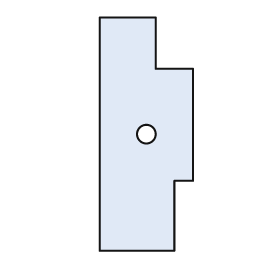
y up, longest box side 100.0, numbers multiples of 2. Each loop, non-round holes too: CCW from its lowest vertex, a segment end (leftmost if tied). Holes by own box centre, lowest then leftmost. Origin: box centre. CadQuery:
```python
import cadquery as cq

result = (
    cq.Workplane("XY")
    .moveTo(-20.0, -50.0)
    .lineTo(12.0, -50.0)
    .lineTo(12.0, -20.0)
    .lineTo(20.0, -20.0)
    .lineTo(20.0, 28.0)
    .lineTo(4.0, 28.0)
    .lineTo(4.0, 50.0)
    .lineTo(-20.0, 50.0)
    .close()
    .moveTo(0.0, 0.0)
    .circle(4.0)
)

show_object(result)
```